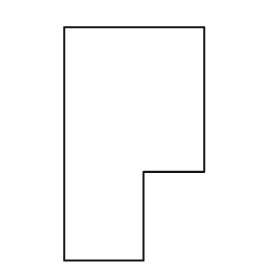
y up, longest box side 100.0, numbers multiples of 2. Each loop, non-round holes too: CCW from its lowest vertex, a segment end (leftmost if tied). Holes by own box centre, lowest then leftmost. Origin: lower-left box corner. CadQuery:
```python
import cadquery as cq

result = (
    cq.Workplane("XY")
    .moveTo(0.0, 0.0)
    .lineTo(34.0, 0.0)
    .lineTo(34.0, 38.0)
    .lineTo(60.0, 38.0)
    .lineTo(60.0, 100.0)
    .lineTo(0.0, 100.0)
    .close()
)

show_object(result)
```